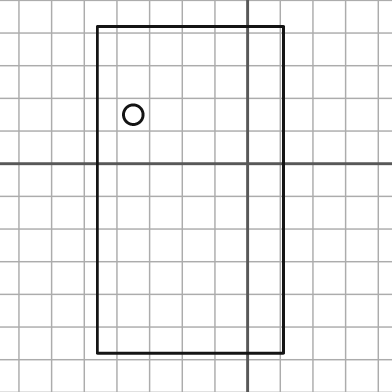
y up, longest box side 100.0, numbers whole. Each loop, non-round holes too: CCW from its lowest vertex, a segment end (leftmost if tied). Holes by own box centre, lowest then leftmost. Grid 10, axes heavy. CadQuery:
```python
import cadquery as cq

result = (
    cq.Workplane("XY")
    .moveTo(-46.0, -58.0)
    .lineTo(11.0, -58.0)
    .lineTo(11.0, 42.0)
    .lineTo(-46.0, 42.0)
    .close()
    .moveTo(-35.0, 15.0)
    .circle(3.0)
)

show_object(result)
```